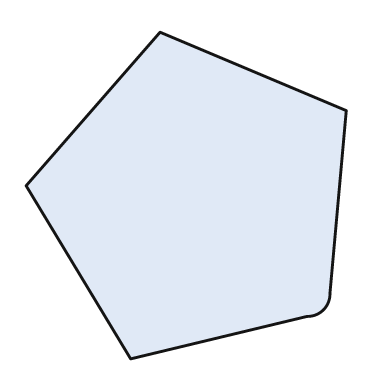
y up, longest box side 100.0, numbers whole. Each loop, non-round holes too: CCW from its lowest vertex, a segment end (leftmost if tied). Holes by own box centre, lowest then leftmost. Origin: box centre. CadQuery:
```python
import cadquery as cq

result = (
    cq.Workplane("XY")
    .moveTo(-17.0, -50.0)
    .lineTo(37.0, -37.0)
    .threePointArc((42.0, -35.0), (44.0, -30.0))
    .lineTo(49.0, 26.0)
    .lineTo(-8.0, 50.0)
    .lineTo(-49.0, 3.0)
    .close()
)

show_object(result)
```